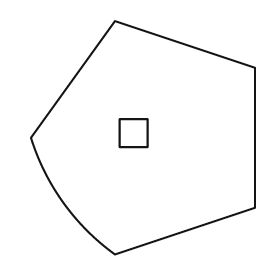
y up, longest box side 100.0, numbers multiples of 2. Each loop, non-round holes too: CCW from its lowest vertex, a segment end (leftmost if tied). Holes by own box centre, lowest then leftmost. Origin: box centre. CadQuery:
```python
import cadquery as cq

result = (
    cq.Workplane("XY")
    .moveTo(-12.0, -50.0)
    .lineTo(48.0, -30.0)
    .lineTo(48.0, 30.0)
    .lineTo(-12.0, 50.0)
    .lineTo(-48.0, 0.0)
    .threePointArc((-34.0, -28.0), (-12.0, -50.0))
    .close()
    .moveTo(-10.0, -4.0)
    .lineTo(2.0, -4.0)
    .lineTo(2.0, 8.0)
    .lineTo(-10.0, 8.0)
    .close()
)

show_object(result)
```